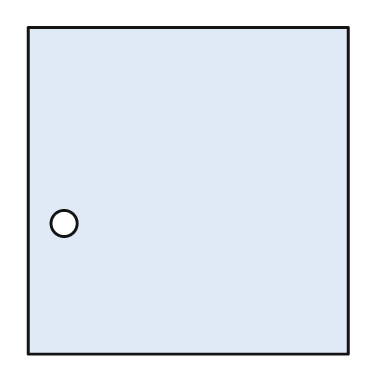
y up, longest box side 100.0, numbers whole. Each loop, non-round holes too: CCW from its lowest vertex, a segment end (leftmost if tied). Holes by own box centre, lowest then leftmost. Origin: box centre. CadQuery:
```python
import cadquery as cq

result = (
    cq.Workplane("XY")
    .moveTo(-49.0, -50.0)
    .lineTo(49.0, -50.0)
    .lineTo(49.0, 50.0)
    .lineTo(-49.0, 50.0)
    .close()
    .moveTo(-38.0, -10.0)
    .circle(4.0)
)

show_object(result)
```